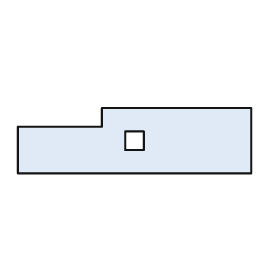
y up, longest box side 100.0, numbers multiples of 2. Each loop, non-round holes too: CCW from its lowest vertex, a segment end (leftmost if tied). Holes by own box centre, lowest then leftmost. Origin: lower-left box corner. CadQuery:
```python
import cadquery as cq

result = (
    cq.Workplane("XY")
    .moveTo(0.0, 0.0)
    .lineTo(100.0, 0.0)
    .lineTo(100.0, 28.0)
    .lineTo(36.0, 28.0)
    .lineTo(36.0, 20.0)
    .lineTo(0.0, 20.0)
    .close()
    .moveTo(46.0, 10.0)
    .lineTo(54.0, 10.0)
    .lineTo(54.0, 18.0)
    .lineTo(46.0, 18.0)
    .close()
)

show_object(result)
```